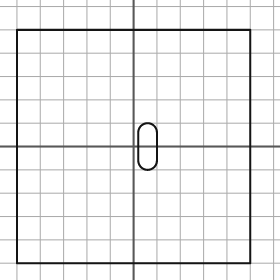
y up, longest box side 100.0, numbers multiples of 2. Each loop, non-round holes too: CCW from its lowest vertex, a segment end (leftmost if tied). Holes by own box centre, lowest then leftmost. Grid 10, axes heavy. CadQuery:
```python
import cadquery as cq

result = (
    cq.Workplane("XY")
    .moveTo(-50.0, -50.0)
    .lineTo(50.0, -50.0)
    .lineTo(50.0, 50.0)
    .lineTo(-50.0, 50.0)
    .close()
    .moveTo(2.0, -6.0)
    .threePointArc((6.0, -10.0), (10.0, -6.0))
    .lineTo(10.0, 6.0)
    .threePointArc((6.0, 10.0), (2.0, 6.0))
    .close()
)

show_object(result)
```